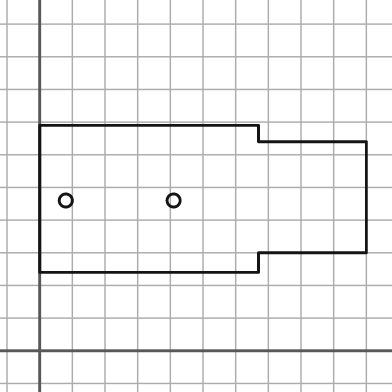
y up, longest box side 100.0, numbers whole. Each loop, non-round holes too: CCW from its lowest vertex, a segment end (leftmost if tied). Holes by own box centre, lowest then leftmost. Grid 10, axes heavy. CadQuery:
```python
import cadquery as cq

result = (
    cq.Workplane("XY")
    .moveTo(0.0, 24.0)
    .lineTo(67.0, 24.0)
    .lineTo(67.0, 30.0)
    .lineTo(100.0, 30.0)
    .lineTo(100.0, 64.0)
    .lineTo(67.0, 64.0)
    .lineTo(67.0, 69.0)
    .lineTo(0.0, 69.0)
    .close()
    .moveTo(8.0, 46.0)
    .circle(2.0)
    .moveTo(41.0, 46.0)
    .circle(2.0)
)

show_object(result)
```